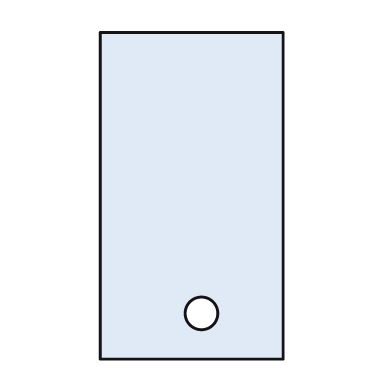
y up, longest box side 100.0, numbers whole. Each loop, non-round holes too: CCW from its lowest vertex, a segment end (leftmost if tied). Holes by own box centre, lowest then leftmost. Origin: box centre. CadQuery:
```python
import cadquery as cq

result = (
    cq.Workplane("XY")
    .moveTo(-28.0, -50.0)
    .lineTo(28.0, -50.0)
    .lineTo(28.0, 50.0)
    .lineTo(-28.0, 50.0)
    .close()
    .moveTo(3.0, -36.0)
    .circle(5.0)
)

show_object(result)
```